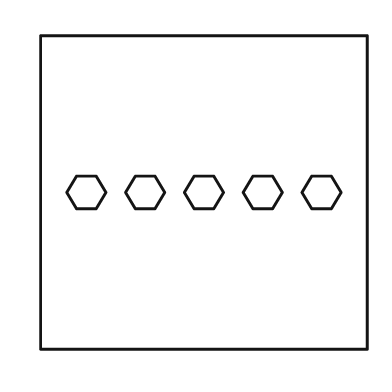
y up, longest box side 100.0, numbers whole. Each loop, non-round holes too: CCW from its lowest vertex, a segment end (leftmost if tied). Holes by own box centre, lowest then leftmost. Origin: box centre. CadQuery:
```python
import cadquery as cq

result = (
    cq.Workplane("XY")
    .moveTo(-50.0, -48.0)
    .lineTo(50.0, -48.0)
    .lineTo(50.0, 48.0)
    .lineTo(-50.0, 48.0)
    .close()
    .moveTo(-39.0, -5.0)
    .lineTo(-33.0, -5.0)
    .lineTo(-30.0, 0.0)
    .lineTo(-33.0, 5.0)
    .lineTo(-39.0, 5.0)
    .lineTo(-42.0, 0.0)
    .close()
    .moveTo(-21.0, -5.0)
    .lineTo(-15.0, -5.0)
    .lineTo(-12.0, 0.0)
    .lineTo(-15.0, 5.0)
    .lineTo(-21.0, 5.0)
    .lineTo(-24.0, 0.0)
    .close()
    .moveTo(-3.0, -5.0)
    .lineTo(3.0, -5.0)
    .lineTo(6.0, 0.0)
    .lineTo(3.0, 5.0)
    .lineTo(-3.0, 5.0)
    .lineTo(-6.0, 0.0)
    .close()
    .moveTo(15.0, -5.0)
    .lineTo(21.0, -5.0)
    .lineTo(24.0, 0.0)
    .lineTo(21.0, 5.0)
    .lineTo(15.0, 5.0)
    .lineTo(12.0, 0.0)
    .close()
    .moveTo(33.0, -5.0)
    .lineTo(39.0, -5.0)
    .lineTo(42.0, 0.0)
    .lineTo(39.0, 5.0)
    .lineTo(33.0, 5.0)
    .lineTo(30.0, 0.0)
    .close()
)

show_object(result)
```